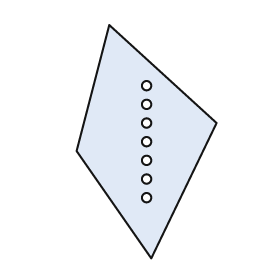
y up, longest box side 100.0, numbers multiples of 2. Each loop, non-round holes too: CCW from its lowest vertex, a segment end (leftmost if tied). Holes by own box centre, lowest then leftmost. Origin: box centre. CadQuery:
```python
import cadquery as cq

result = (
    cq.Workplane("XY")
    .moveTo(2.0, -50.0)
    .lineTo(30.0, 8.0)
    .lineTo(-16.0, 50.0)
    .lineTo(-30.0, -4.0)
    .close()
    .moveTo(0.0, -24.0)
    .circle(2.0)
    .moveTo(0.0, -16.0)
    .circle(2.0)
    .moveTo(0.0, -8.0)
    .circle(2.0)
    .moveTo(0.0, 0.0)
    .circle(2.0)
    .moveTo(0.0, 8.0)
    .circle(2.0)
    .moveTo(0.0, 16.0)
    .circle(2.0)
    .moveTo(0.0, 24.0)
    .circle(2.0)
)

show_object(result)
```